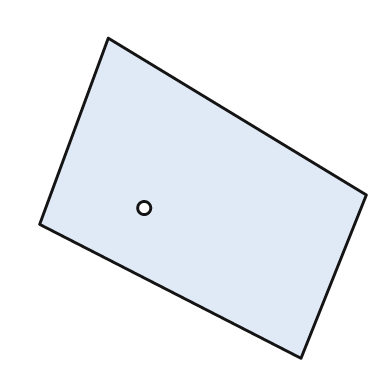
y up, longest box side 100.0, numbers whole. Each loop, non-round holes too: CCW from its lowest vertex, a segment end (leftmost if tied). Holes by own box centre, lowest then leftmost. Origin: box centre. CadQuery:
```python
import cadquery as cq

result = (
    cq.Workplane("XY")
    .moveTo(30.0, -49.0)
    .lineTo(50.0, 1.0)
    .lineTo(-29.0, 49.0)
    .lineTo(-50.0, -8.0)
    .close()
    .moveTo(-18.0, -3.0)
    .circle(2.0)
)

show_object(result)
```